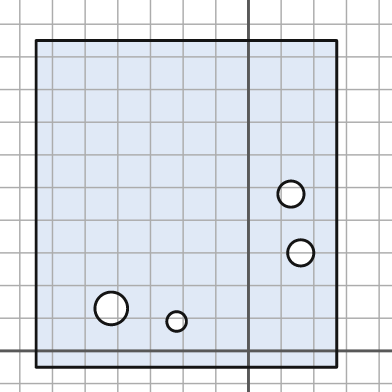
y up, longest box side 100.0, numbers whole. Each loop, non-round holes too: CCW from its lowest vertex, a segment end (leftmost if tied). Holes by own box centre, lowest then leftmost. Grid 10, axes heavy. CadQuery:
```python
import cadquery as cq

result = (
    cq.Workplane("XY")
    .moveTo(-65.0, -5.0)
    .lineTo(27.0, -5.0)
    .lineTo(27.0, 95.0)
    .lineTo(-65.0, 95.0)
    .close()
    .moveTo(-22.0, 9.0)
    .circle(3.0)
    .moveTo(-42.0, 13.0)
    .circle(5.0)
    .moveTo(16.0, 30.0)
    .circle(4.0)
    .moveTo(13.0, 48.0)
    .circle(4.0)
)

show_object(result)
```